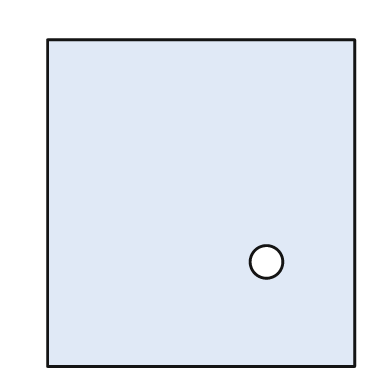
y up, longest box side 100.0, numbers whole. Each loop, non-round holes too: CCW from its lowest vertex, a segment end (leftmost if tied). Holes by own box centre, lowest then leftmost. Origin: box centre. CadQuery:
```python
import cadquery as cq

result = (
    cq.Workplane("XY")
    .moveTo(-47.0, -50.0)
    .lineTo(47.0, -50.0)
    .lineTo(47.0, 50.0)
    .lineTo(-47.0, 50.0)
    .close()
    .moveTo(20.0, -18.0)
    .circle(5.0)
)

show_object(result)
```